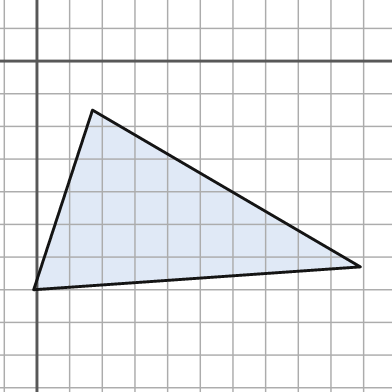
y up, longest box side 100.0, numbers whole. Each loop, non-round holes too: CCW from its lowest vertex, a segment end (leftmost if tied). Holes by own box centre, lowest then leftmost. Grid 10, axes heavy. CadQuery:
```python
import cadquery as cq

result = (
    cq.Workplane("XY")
    .moveTo(-1.0, -70.0)
    .lineTo(99.0, -63.0)
    .lineTo(17.0, -15.0)
    .close()
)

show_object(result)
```